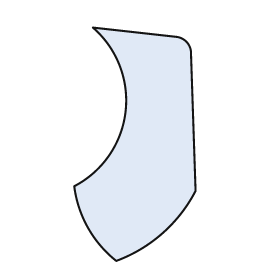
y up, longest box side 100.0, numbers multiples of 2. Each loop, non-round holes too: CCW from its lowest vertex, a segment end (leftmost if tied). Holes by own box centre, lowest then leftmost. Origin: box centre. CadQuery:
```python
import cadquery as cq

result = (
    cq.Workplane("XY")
    .moveTo(-8.0, -50.0)
    .threePointArc((12.0, -38.0), (26.0, -20.0))
    .lineTo(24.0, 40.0)
    .threePointArc((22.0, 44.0), (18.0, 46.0))
    .lineTo(-18.0, 50.0)
    .threePointArc((-4.0, 14.0), (-26.0, -18.0))
    .threePointArc((-20.0, -36.0), (-8.0, -50.0))
    .close()
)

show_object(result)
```